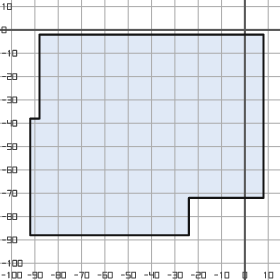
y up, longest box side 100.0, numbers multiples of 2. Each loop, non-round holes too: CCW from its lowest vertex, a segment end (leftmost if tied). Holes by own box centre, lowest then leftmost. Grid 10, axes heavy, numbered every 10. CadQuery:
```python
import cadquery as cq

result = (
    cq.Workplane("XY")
    .moveTo(-92.0, -88.0)
    .lineTo(-24.0, -88.0)
    .lineTo(-24.0, -72.0)
    .lineTo(8.0, -72.0)
    .lineTo(8.0, -2.0)
    .lineTo(-88.0, -2.0)
    .lineTo(-88.0, -38.0)
    .lineTo(-92.0, -38.0)
    .close()
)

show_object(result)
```